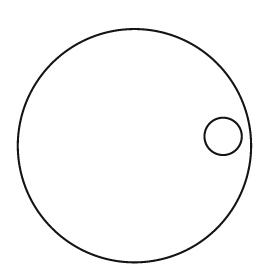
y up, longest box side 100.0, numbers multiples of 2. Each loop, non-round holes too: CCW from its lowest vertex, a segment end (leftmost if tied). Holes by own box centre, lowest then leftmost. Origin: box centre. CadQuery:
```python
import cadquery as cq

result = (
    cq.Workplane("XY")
    .moveTo(0.0, 0.0)
    .circle(50.0)
    .moveTo(38.0, 4.0)
    .circle(8.0)
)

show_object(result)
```